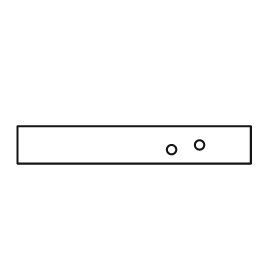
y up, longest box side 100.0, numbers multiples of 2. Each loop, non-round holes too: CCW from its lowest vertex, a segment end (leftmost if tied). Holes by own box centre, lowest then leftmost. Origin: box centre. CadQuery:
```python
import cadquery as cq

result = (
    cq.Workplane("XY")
    .moveTo(-50.0, -8.0)
    .lineTo(50.0, -8.0)
    .lineTo(50.0, 8.0)
    .lineTo(-50.0, 8.0)
    .close()
    .moveTo(16.0, -2.0)
    .circle(2.0)
    .moveTo(28.0, 0.0)
    .circle(2.0)
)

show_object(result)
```